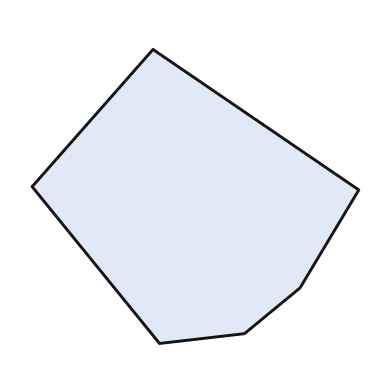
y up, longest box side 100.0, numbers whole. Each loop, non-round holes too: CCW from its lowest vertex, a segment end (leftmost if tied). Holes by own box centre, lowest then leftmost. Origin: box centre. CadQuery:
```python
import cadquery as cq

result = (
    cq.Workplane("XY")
    .moveTo(-11.0, -45.0)
    .lineTo(15.0, -42.0)
    .lineTo(32.0, -28.0)
    .lineTo(50.0, 2.0)
    .lineTo(-13.0, 45.0)
    .lineTo(-50.0, 3.0)
    .close()
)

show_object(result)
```